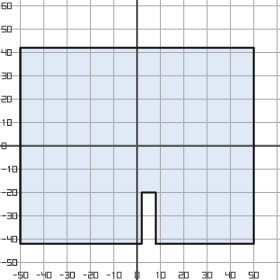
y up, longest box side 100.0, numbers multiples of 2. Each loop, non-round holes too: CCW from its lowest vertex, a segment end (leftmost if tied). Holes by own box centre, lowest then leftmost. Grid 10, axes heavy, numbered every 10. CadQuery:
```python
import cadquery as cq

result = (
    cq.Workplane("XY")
    .moveTo(-50.0, -42.0)
    .lineTo(2.0, -42.0)
    .lineTo(2.0, -20.0)
    .lineTo(8.0, -20.0)
    .lineTo(8.0, -42.0)
    .lineTo(50.0, -42.0)
    .lineTo(50.0, 42.0)
    .lineTo(-50.0, 42.0)
    .close()
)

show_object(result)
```